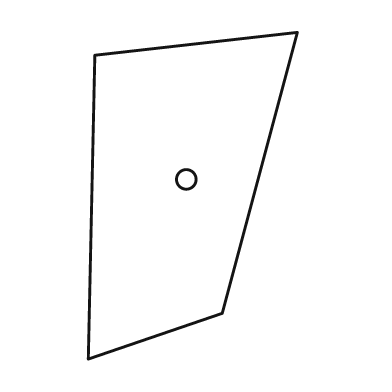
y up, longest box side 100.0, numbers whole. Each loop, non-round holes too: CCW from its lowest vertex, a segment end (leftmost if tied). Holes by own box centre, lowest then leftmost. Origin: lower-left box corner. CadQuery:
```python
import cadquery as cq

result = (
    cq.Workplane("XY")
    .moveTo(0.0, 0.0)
    .lineTo(41.0, 14.0)
    .lineTo(64.0, 100.0)
    .lineTo(2.0, 93.0)
    .close()
    .moveTo(30.0, 55.0)
    .circle(3.0)
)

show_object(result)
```